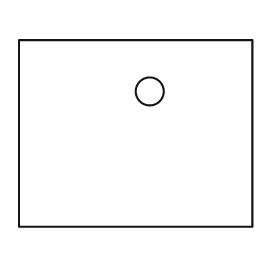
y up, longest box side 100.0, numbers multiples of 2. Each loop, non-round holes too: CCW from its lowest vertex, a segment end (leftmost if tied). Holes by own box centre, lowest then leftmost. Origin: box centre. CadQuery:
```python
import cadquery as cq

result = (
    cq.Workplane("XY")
    .moveTo(-50.0, -40.0)
    .lineTo(50.0, -40.0)
    .lineTo(50.0, 40.0)
    .lineTo(-50.0, 40.0)
    .close()
    .moveTo(6.0, 18.0)
    .circle(6.0)
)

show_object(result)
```